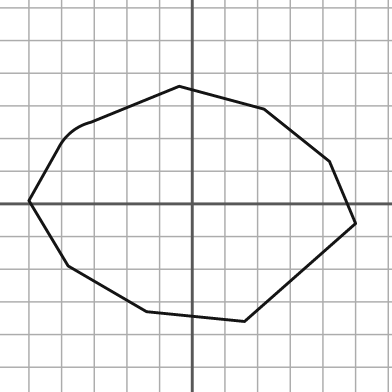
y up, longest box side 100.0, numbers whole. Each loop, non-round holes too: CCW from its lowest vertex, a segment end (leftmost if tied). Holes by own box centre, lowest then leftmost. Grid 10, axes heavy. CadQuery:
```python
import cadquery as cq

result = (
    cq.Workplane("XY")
    .moveTo(16.0, -36.0)
    .lineTo(50.0, -6.0)
    .lineTo(42.0, 13.0)
    .lineTo(22.0, 29.0)
    .lineTo(-4.0, 36.0)
    .lineTo(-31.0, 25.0)
    .threePointArc((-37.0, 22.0), (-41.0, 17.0))
    .lineTo(-50.0, 1.0)
    .lineTo(-38.0, -19.0)
    .lineTo(-14.0, -33.0)
    .close()
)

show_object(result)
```